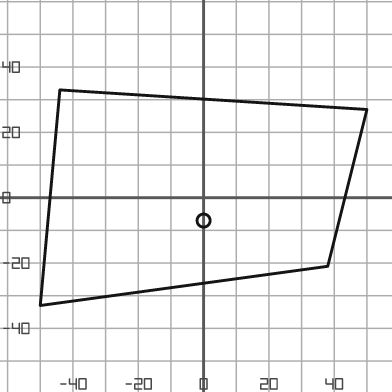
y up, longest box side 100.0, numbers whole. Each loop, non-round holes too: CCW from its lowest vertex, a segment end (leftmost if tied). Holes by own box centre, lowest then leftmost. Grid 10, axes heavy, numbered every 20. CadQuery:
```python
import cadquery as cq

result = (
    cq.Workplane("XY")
    .moveTo(-50.0, -33.0)
    .lineTo(38.0, -21.0)
    .lineTo(50.0, 27.0)
    .lineTo(-44.0, 33.0)
    .close()
    .moveTo(0.0, -7.0)
    .circle(2.0)
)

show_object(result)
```